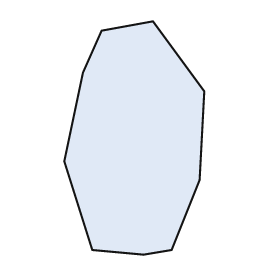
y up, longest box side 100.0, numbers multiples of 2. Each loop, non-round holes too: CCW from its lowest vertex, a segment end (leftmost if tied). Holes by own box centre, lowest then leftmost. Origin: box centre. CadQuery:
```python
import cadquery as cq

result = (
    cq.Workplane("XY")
    .moveTo(4.0, -50.0)
    .lineTo(16.0, -48.0)
    .lineTo(28.0, -18.0)
    .lineTo(30.0, 20.0)
    .lineTo(8.0, 50.0)
    .lineTo(-14.0, 46.0)
    .lineTo(-22.0, 28.0)
    .lineTo(-30.0, -10.0)
    .lineTo(-18.0, -48.0)
    .close()
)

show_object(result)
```